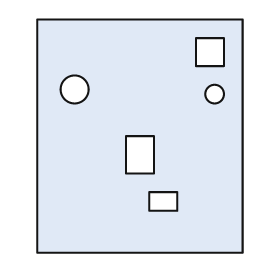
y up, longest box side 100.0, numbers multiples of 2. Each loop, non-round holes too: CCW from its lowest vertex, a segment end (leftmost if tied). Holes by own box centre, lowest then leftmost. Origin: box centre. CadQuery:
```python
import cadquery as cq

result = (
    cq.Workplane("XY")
    .moveTo(-44.0, -50.0)
    .lineTo(44.0, -50.0)
    .lineTo(44.0, 50.0)
    .lineTo(-44.0, 50.0)
    .close()
    .moveTo(4.0, -32.0)
    .lineTo(16.0, -32.0)
    .lineTo(16.0, -24.0)
    .lineTo(4.0, -24.0)
    .close()
    .moveTo(-6.0, -16.0)
    .lineTo(6.0, -16.0)
    .lineTo(6.0, 0.0)
    .lineTo(-6.0, 0.0)
    .close()
    .moveTo(32.0, 18.0)
    .circle(4.0)
    .moveTo(-28.0, 20.0)
    .circle(6.0)
    .moveTo(24.0, 30.0)
    .lineTo(36.0, 30.0)
    .lineTo(36.0, 42.0)
    .lineTo(24.0, 42.0)
    .close()
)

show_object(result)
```